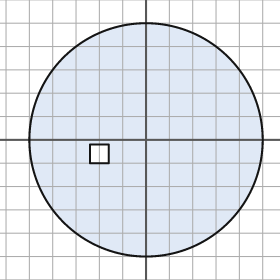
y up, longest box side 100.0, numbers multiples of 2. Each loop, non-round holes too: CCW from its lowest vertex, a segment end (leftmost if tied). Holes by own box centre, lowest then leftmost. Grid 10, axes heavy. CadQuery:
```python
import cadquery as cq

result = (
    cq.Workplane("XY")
    .moveTo(0.0, 0.0)
    .circle(50.0)
    .moveTo(-24.0, -10.0)
    .lineTo(-16.0, -10.0)
    .lineTo(-16.0, -2.0)
    .lineTo(-24.0, -2.0)
    .close()
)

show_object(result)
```